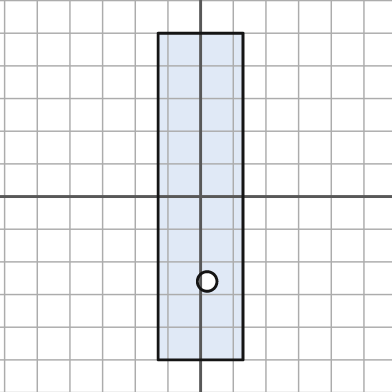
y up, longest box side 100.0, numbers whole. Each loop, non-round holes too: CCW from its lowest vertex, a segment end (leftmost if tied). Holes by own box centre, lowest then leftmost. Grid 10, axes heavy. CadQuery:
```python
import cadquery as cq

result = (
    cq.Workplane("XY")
    .moveTo(-13.0, -50.0)
    .lineTo(13.0, -50.0)
    .lineTo(13.0, 50.0)
    .lineTo(-13.0, 50.0)
    .close()
    .moveTo(2.0, -26.0)
    .circle(3.0)
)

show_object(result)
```